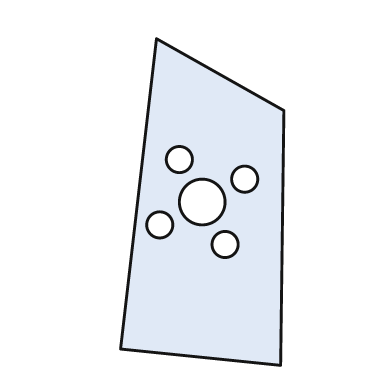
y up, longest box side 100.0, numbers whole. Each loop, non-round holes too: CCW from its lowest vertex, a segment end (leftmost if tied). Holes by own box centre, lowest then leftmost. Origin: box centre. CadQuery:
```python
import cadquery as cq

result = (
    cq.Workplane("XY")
    .moveTo(24.0, -50.0)
    .lineTo(25.0, 28.0)
    .lineTo(-14.0, 50.0)
    .lineTo(-25.0, -45.0)
    .close()
    .moveTo(7.0, -13.0)
    .circle(4.0)
    .moveTo(-13.0, -7.0)
    .circle(4.0)
    .moveTo(0.0, 0.0)
    .circle(7.0)
    .moveTo(13.0, 7.0)
    .circle(4.0)
    .moveTo(-7.0, 13.0)
    .circle(4.0)
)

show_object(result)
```